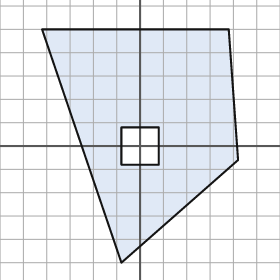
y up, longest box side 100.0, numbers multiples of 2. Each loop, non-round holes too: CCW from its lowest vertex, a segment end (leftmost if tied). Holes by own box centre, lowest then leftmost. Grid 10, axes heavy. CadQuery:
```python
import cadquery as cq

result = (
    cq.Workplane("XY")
    .moveTo(-8.0, -50.0)
    .lineTo(42.0, -6.0)
    .lineTo(38.0, 50.0)
    .lineTo(-42.0, 50.0)
    .close()
    .moveTo(-8.0, -8.0)
    .lineTo(8.0, -8.0)
    .lineTo(8.0, 8.0)
    .lineTo(-8.0, 8.0)
    .close()
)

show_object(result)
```